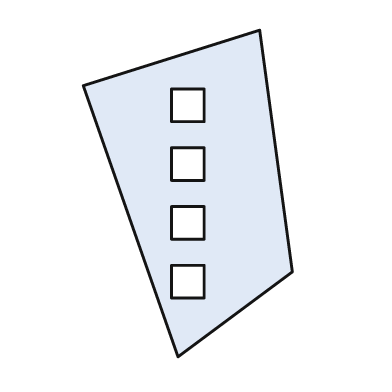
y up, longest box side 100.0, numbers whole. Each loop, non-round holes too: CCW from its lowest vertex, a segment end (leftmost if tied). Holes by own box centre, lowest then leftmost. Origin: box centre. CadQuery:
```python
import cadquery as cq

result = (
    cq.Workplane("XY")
    .moveTo(-3.0, -50.0)
    .lineTo(32.0, -24.0)
    .lineTo(22.0, 50.0)
    .lineTo(-32.0, 33.0)
    .close()
    .moveTo(-5.0, -32.0)
    .lineTo(5.0, -32.0)
    .lineTo(5.0, -22.0)
    .lineTo(-5.0, -22.0)
    .close()
    .moveTo(-5.0, -14.0)
    .lineTo(5.0, -14.0)
    .lineTo(5.0, -4.0)
    .lineTo(-5.0, -4.0)
    .close()
    .moveTo(-5.0, 4.0)
    .lineTo(5.0, 4.0)
    .lineTo(5.0, 14.0)
    .lineTo(-5.0, 14.0)
    .close()
    .moveTo(-5.0, 22.0)
    .lineTo(5.0, 22.0)
    .lineTo(5.0, 32.0)
    .lineTo(-5.0, 32.0)
    .close()
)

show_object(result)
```